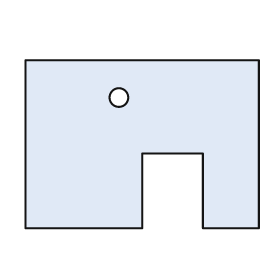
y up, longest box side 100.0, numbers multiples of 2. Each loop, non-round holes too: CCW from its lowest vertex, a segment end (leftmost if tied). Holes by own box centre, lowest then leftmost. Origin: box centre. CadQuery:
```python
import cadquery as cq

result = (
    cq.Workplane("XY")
    .moveTo(-50.0, -36.0)
    .lineTo(0.0, -36.0)
    .lineTo(0.0, -4.0)
    .lineTo(26.0, -4.0)
    .lineTo(26.0, -36.0)
    .lineTo(50.0, -36.0)
    .lineTo(50.0, 36.0)
    .lineTo(-50.0, 36.0)
    .close()
    .moveTo(-10.0, 20.0)
    .circle(4.0)
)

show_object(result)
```